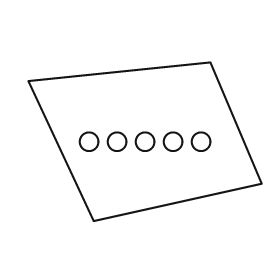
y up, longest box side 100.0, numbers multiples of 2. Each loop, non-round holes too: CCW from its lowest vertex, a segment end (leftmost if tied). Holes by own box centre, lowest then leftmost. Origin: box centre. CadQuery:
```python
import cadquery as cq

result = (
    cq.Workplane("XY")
    .moveTo(-22.0, -34.0)
    .lineTo(50.0, -18.0)
    .lineTo(28.0, 34.0)
    .lineTo(-50.0, 26.0)
    .close()
    .moveTo(-24.0, 0.0)
    .circle(4.0)
    .moveTo(-12.0, 0.0)
    .circle(4.0)
    .moveTo(0.0, 0.0)
    .circle(4.0)
    .moveTo(12.0, 0.0)
    .circle(4.0)
    .moveTo(24.0, 0.0)
    .circle(4.0)
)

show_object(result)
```